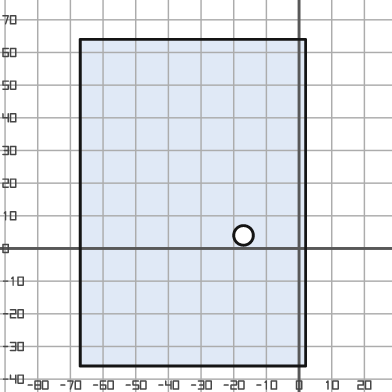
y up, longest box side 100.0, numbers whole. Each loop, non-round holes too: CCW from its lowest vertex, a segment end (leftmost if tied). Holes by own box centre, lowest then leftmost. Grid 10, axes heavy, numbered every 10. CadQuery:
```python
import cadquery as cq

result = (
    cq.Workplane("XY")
    .moveTo(-67.0, -36.0)
    .lineTo(2.0, -36.0)
    .lineTo(2.0, 64.0)
    .lineTo(-67.0, 64.0)
    .close()
    .moveTo(-17.0, 4.0)
    .circle(3.0)
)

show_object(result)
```